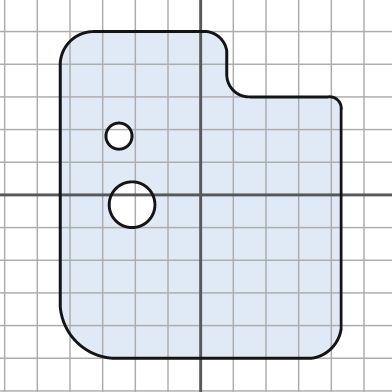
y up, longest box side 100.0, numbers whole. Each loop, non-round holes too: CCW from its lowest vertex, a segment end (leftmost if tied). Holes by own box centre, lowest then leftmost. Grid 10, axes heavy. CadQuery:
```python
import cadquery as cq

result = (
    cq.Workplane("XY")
    .moveTo(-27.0, -50.0)
    .lineTo(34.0, -50.0)
    .threePointArc((40.0, -47.0), (43.0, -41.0))
    .lineTo(43.0, 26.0)
    .threePointArc((42.0, 29.0), (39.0, 30.0))
    .lineTo(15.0, 30.0)
    .threePointArc((10.0, 32.0), (8.0, 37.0))
    .lineTo(8.0, 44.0)
    .threePointArc((6.0, 48.0), (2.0, 50.0))
    .lineTo(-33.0, 50.0)
    .threePointArc((-40.0, 47.0), (-43.0, 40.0))
    .lineTo(-43.0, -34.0)
    .threePointArc((-38.0, -45.0), (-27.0, -50.0))
    .close()
    .moveTo(-21.0, -3.0)
    .circle(7.0)
    .moveTo(-25.0, 18.0)
    .circle(4.0)
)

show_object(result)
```